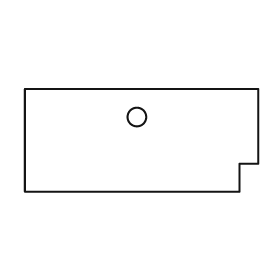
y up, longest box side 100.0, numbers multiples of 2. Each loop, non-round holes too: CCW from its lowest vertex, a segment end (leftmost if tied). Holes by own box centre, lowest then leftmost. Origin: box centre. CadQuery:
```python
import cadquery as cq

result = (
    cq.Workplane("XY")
    .moveTo(-50.0, -22.0)
    .lineTo(42.0, -22.0)
    .lineTo(42.0, -10.0)
    .lineTo(50.0, -10.0)
    .lineTo(50.0, 22.0)
    .lineTo(-50.0, 22.0)
    .close()
    .moveTo(-2.0, 10.0)
    .circle(4.0)
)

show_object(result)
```